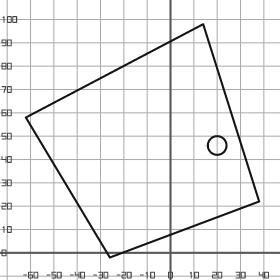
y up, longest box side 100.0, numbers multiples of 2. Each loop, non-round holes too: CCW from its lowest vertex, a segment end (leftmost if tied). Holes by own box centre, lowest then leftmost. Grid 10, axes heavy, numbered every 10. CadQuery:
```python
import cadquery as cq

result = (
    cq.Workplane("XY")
    .moveTo(-26.0, -2.0)
    .lineTo(38.0, 22.0)
    .lineTo(14.0, 98.0)
    .lineTo(-62.0, 58.0)
    .close()
    .moveTo(20.0, 46.0)
    .circle(4.0)
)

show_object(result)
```